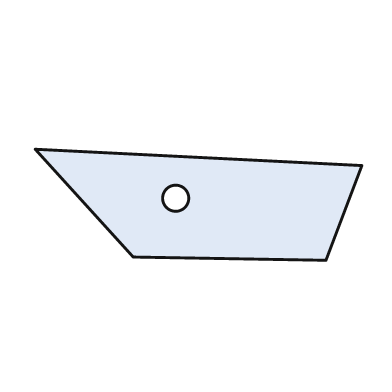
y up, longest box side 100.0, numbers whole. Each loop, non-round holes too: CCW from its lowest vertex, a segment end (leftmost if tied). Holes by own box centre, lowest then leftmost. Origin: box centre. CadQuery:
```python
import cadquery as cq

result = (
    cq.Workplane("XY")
    .moveTo(39.0, -17.0)
    .lineTo(50.0, 12.0)
    .lineTo(-50.0, 17.0)
    .lineTo(-20.0, -16.0)
    .close()
    .moveTo(-7.0, 2.0)
    .circle(4.0)
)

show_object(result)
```